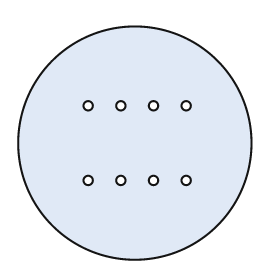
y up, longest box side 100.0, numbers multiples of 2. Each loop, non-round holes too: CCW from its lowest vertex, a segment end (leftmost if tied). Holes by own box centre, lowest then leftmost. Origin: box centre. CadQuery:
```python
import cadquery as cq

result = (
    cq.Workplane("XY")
    .moveTo(0.0, 0.0)
    .circle(50.0)
    .moveTo(-20.0, -16.0)
    .circle(2.0)
    .moveTo(-6.0, -16.0)
    .circle(2.0)
    .moveTo(8.0, -16.0)
    .circle(2.0)
    .moveTo(22.0, -16.0)
    .circle(2.0)
    .moveTo(-20.0, 16.0)
    .circle(2.0)
    .moveTo(-6.0, 16.0)
    .circle(2.0)
    .moveTo(8.0, 16.0)
    .circle(2.0)
    .moveTo(22.0, 16.0)
    .circle(2.0)
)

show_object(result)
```